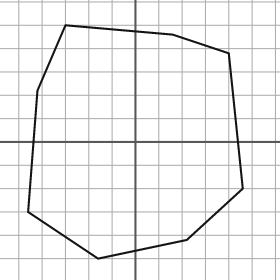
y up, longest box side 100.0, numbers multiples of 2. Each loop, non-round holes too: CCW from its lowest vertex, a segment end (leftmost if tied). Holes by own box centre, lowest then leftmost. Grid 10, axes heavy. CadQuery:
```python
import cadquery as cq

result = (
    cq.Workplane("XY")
    .moveTo(-16.0, -50.0)
    .lineTo(22.0, -42.0)
    .lineTo(46.0, -20.0)
    .lineTo(40.0, 38.0)
    .lineTo(16.0, 46.0)
    .lineTo(-30.0, 50.0)
    .lineTo(-42.0, 22.0)
    .lineTo(-46.0, -30.0)
    .close()
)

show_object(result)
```